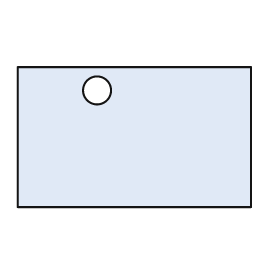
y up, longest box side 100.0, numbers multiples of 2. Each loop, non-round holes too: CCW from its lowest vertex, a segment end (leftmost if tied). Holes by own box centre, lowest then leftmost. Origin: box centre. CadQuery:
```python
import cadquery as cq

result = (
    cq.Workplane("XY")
    .moveTo(-50.0, -30.0)
    .lineTo(50.0, -30.0)
    .lineTo(50.0, 30.0)
    .lineTo(-50.0, 30.0)
    .close()
    .moveTo(-16.0, 20.0)
    .circle(6.0)
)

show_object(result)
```